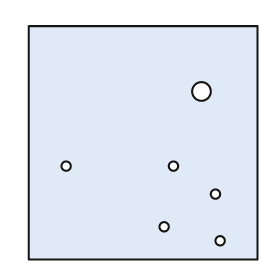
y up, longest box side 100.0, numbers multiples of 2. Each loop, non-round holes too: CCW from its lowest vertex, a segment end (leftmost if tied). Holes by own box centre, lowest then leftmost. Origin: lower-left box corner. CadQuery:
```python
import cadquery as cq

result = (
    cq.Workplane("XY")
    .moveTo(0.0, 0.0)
    .lineTo(98.0, 0.0)
    .lineTo(98.0, 100.0)
    .lineTo(0.0, 100.0)
    .close()
    .moveTo(82.0, 8.0)
    .circle(2.0)
    .moveTo(58.0, 14.0)
    .circle(2.0)
    .moveTo(80.0, 28.0)
    .circle(2.0)
    .moveTo(16.0, 40.0)
    .circle(2.0)
    .moveTo(62.0, 40.0)
    .circle(2.0)
    .moveTo(74.0, 72.0)
    .circle(4.0)
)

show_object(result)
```